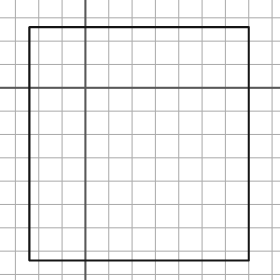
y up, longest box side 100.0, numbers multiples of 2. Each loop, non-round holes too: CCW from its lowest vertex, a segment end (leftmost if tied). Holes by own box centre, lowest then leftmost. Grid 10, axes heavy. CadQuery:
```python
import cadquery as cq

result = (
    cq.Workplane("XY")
    .moveTo(-24.0, -74.0)
    .lineTo(70.0, -74.0)
    .lineTo(70.0, 26.0)
    .lineTo(-24.0, 26.0)
    .close()
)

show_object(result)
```